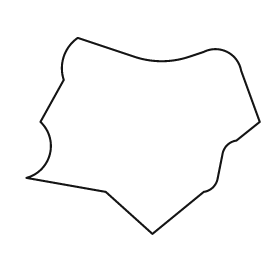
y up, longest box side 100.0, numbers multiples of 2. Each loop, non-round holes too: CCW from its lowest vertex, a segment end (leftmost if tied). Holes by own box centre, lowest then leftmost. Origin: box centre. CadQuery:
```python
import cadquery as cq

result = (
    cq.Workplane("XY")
    .moveTo(4.0, -42.0)
    .lineTo(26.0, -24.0)
    .threePointArc((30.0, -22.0), (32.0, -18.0))
    .lineTo(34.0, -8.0)
    .threePointArc((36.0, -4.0), (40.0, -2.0))
    .lineTo(50.0, 6.0)
    .lineTo(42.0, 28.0)
    .threePointArc((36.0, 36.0), (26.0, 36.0))
    .lineTo(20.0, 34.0)
    .threePointArc((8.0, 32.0), (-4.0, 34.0))
    .lineTo(-28.0, 42.0)
    .threePointArc((-34.0, 34.0), (-34.0, 24.0))
    .lineTo(-44.0, 6.0)
    .threePointArc((-40.0, -8.0), (-50.0, -18.0))
    .lineTo(-16.0, -24.0)
    .close()
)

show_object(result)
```